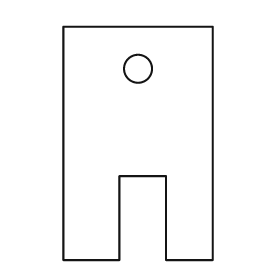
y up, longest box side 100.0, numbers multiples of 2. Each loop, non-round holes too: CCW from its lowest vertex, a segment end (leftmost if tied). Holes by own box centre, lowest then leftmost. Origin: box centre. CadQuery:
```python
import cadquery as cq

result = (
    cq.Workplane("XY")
    .moveTo(-32.0, -50.0)
    .lineTo(-8.0, -50.0)
    .lineTo(-8.0, -14.0)
    .lineTo(12.0, -14.0)
    .lineTo(12.0, -50.0)
    .lineTo(32.0, -50.0)
    .lineTo(32.0, 50.0)
    .lineTo(-32.0, 50.0)
    .close()
    .moveTo(0.0, 32.0)
    .circle(6.0)
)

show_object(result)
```